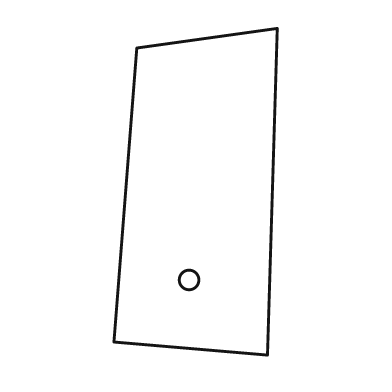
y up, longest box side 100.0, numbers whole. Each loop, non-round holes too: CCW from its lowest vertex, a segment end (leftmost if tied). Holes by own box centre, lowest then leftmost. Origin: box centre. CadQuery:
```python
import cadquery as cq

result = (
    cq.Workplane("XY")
    .moveTo(22.0, -50.0)
    .lineTo(25.0, 50.0)
    .lineTo(-18.0, 44.0)
    .lineTo(-25.0, -46.0)
    .close()
    .moveTo(-2.0, -27.0)
    .circle(3.0)
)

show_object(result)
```